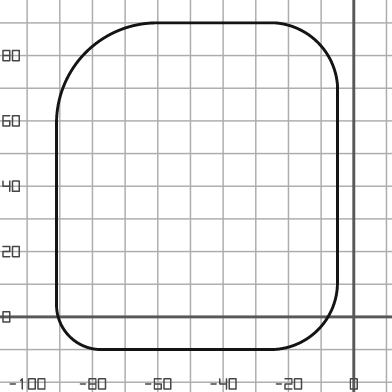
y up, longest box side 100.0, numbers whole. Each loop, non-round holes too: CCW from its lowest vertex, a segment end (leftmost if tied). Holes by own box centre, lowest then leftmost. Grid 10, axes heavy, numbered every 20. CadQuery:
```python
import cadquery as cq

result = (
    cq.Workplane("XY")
    .moveTo(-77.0, -10.0)
    .lineTo(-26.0, -10.0)
    .threePointArc((-11.0, -4.0), (-5.0, 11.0))
    .lineTo(-5.0, 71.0)
    .threePointArc((-11.0, 84.0), (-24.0, 90.0))
    .lineTo(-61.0, 90.0)
    .threePointArc((-82.0, 81.0), (-91.0, 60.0))
    .lineTo(-91.0, 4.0)
    .threePointArc((-87.0, -6.0), (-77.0, -10.0))
    .close()
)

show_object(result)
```